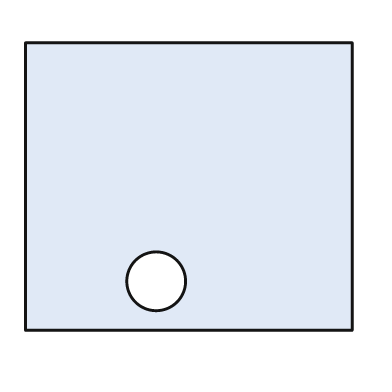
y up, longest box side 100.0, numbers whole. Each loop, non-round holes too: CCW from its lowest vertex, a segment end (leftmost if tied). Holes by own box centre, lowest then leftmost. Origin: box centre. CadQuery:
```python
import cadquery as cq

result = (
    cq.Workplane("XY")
    .moveTo(-50.0, -44.0)
    .lineTo(50.0, -44.0)
    .lineTo(50.0, 44.0)
    .lineTo(-50.0, 44.0)
    .close()
    .moveTo(-10.0, -29.0)
    .circle(9.0)
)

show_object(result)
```